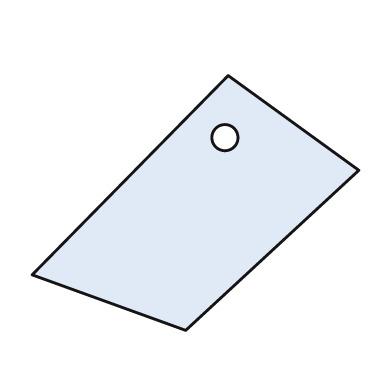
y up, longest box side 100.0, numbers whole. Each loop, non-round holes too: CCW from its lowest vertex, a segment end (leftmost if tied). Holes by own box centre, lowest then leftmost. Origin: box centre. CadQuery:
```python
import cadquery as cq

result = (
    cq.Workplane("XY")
    .moveTo(-3.0, -39.0)
    .lineTo(50.0, 10.0)
    .lineTo(10.0, 39.0)
    .lineTo(-50.0, -22.0)
    .close()
    .moveTo(9.0, 20.0)
    .circle(4.0)
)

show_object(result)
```